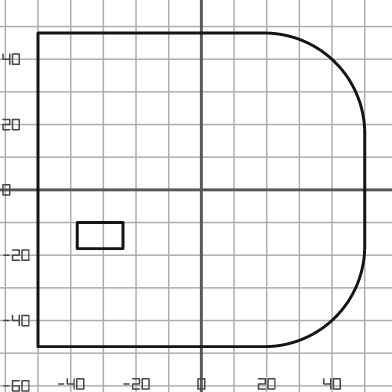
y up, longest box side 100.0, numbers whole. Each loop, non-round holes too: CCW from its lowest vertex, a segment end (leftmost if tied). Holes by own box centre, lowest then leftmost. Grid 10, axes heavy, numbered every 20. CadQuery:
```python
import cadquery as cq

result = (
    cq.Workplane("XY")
    .moveTo(-50.0, -48.0)
    .lineTo(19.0, -48.0)
    .threePointArc((41.0, -39.0), (50.0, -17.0))
    .lineTo(50.0, 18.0)
    .threePointArc((41.0, 39.0), (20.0, 48.0))
    .lineTo(-50.0, 48.0)
    .close()
    .moveTo(-38.0, -18.0)
    .lineTo(-24.0, -18.0)
    .lineTo(-24.0, -10.0)
    .lineTo(-38.0, -10.0)
    .close()
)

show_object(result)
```